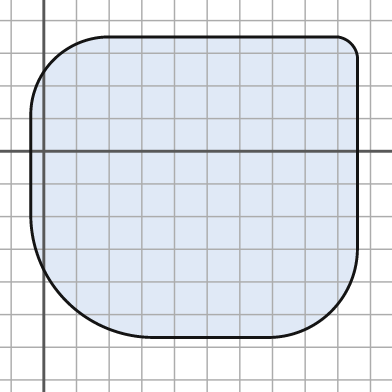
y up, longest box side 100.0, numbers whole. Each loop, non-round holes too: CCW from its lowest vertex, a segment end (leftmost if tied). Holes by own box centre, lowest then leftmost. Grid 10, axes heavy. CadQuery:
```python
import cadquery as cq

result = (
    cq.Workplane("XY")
    .moveTo(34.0, -57.0)
    .lineTo(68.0, -57.0)
    .threePointArc((88.0, -49.0), (96.0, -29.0))
    .lineTo(96.0, 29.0)
    .threePointArc((94.0, 33.0), (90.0, 35.0))
    .lineTo(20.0, 35.0)
    .threePointArc((3.0, 28.0), (-4.0, 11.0))
    .lineTo(-4.0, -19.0)
    .threePointArc((7.0, -46.0), (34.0, -57.0))
    .close()
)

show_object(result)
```